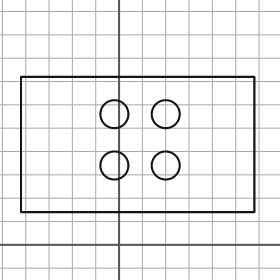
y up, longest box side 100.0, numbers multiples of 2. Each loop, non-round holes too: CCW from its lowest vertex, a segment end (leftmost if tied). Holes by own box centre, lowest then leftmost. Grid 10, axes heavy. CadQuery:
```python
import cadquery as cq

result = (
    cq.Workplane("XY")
    .moveTo(-42.0, 14.0)
    .lineTo(58.0, 14.0)
    .lineTo(58.0, 72.0)
    .lineTo(-42.0, 72.0)
    .close()
    .moveTo(-2.0, 34.0)
    .circle(6.0)
    .moveTo(20.0, 34.0)
    .circle(6.0)
    .moveTo(-2.0, 56.0)
    .circle(6.0)
    .moveTo(20.0, 56.0)
    .circle(6.0)
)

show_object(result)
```